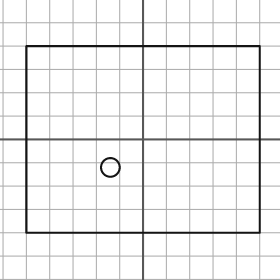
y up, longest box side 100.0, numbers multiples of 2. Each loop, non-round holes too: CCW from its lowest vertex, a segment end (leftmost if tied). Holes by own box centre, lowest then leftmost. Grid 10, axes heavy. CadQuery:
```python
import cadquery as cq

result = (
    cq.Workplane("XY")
    .moveTo(-50.0, -40.0)
    .lineTo(50.0, -40.0)
    .lineTo(50.0, 40.0)
    .lineTo(-50.0, 40.0)
    .close()
    .moveTo(-14.0, -12.0)
    .circle(4.0)
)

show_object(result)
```